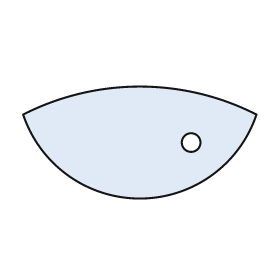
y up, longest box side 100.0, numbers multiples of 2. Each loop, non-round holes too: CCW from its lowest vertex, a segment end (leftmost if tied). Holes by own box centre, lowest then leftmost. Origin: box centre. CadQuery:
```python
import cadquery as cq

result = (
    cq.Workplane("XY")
    .moveTo(-50.0, 12.0)
    .threePointArc((0.0, -24.0), (50.0, 12.0))
    .threePointArc((0.0, 24.0), (-50.0, 12.0))
    .close()
    .moveTo(22.0, 0.0)
    .circle(4.0)
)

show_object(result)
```